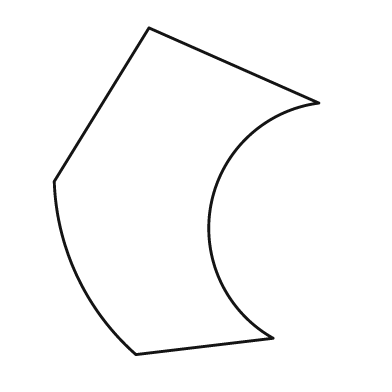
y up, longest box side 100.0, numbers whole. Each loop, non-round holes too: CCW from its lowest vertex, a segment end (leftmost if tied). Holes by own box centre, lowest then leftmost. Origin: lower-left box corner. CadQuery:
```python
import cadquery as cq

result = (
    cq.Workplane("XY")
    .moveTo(25.0, 0.0)
    .lineTo(67.0, 5.0)
    .threePointArc((48.0, 46.0), (81.0, 77.0))
    .lineTo(29.0, 100.0)
    .lineTo(0.0, 53.0)
    .threePointArc((7.0, 24.0), (25.0, 0.0))
    .close()
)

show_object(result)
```